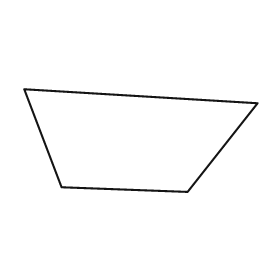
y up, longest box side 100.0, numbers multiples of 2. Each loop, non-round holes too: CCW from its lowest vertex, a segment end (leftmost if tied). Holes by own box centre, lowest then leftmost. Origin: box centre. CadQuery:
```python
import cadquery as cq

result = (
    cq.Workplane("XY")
    .moveTo(20.0, -22.0)
    .lineTo(50.0, 16.0)
    .lineTo(-50.0, 22.0)
    .lineTo(-34.0, -20.0)
    .close()
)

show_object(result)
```